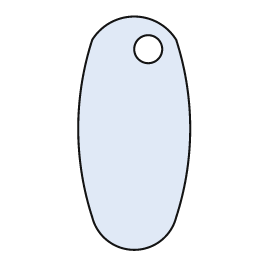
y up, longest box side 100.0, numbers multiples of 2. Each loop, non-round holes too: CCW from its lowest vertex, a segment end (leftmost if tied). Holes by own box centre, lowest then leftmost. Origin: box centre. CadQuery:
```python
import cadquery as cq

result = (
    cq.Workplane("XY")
    .moveTo(-18.0, -36.0)
    .threePointArc((0.0, -50.0), (18.0, -36.0))
    .threePointArc((24.0, 2.0), (18.0, 40.0))
    .threePointArc((0.0, 50.0), (-18.0, 40.0))
    .threePointArc((-24.0, 2.0), (-18.0, -36.0))
    .close()
    .moveTo(6.0, 36.0)
    .circle(6.0)
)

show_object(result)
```